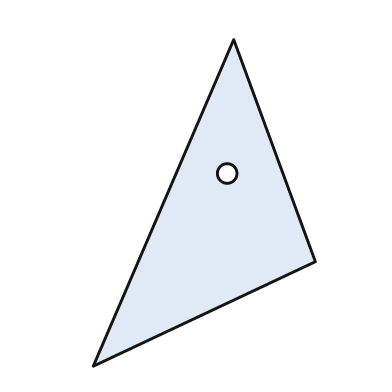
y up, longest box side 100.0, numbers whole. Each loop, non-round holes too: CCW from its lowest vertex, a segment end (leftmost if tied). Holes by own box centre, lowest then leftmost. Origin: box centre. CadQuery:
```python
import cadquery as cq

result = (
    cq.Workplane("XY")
    .moveTo(-34.0, -50.0)
    .lineTo(34.0, -18.0)
    .lineTo(9.0, 50.0)
    .close()
    .moveTo(7.0, 9.0)
    .circle(3.0)
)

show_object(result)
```